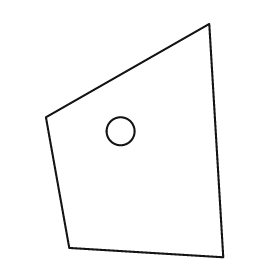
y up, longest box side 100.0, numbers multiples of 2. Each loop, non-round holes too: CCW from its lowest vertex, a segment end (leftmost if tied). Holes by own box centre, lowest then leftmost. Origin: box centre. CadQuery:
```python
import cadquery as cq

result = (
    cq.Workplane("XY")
    .moveTo(38.0, -50.0)
    .lineTo(32.0, 50.0)
    .lineTo(-38.0, 10.0)
    .lineTo(-28.0, -46.0)
    .close()
    .moveTo(-6.0, 4.0)
    .circle(6.0)
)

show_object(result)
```